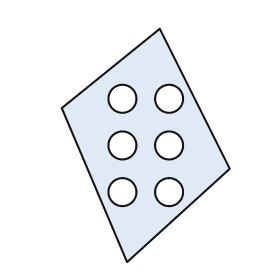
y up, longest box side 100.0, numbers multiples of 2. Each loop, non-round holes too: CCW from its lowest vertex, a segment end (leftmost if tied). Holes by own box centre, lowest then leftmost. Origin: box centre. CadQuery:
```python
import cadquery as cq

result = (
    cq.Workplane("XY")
    .moveTo(-8.0, -50.0)
    .lineTo(36.0, -10.0)
    .lineTo(6.0, 50.0)
    .lineTo(-36.0, 16.0)
    .close()
    .moveTo(-10.0, -20.0)
    .circle(6.0)
    .moveTo(10.0, -20.0)
    .circle(6.0)
    .moveTo(-10.0, 0.0)
    .circle(6.0)
    .moveTo(10.0, 0.0)
    .circle(6.0)
    .moveTo(-10.0, 20.0)
    .circle(6.0)
    .moveTo(10.0, 20.0)
    .circle(6.0)
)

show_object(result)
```